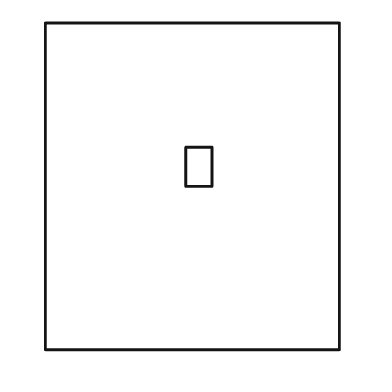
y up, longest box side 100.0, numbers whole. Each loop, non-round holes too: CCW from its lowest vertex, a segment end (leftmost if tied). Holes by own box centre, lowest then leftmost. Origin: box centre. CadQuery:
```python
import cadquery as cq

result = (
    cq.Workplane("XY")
    .moveTo(-45.0, -50.0)
    .lineTo(45.0, -50.0)
    .lineTo(45.0, 50.0)
    .lineTo(-45.0, 50.0)
    .close()
    .moveTo(-2.0, 0.0)
    .lineTo(6.0, 0.0)
    .lineTo(6.0, 12.0)
    .lineTo(-2.0, 12.0)
    .close()
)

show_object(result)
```